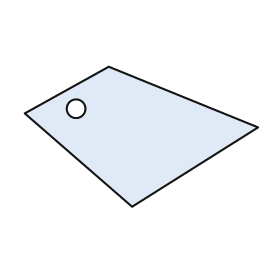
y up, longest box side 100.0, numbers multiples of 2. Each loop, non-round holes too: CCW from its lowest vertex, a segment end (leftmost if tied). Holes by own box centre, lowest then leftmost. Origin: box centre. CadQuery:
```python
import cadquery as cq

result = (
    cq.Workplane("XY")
    .moveTo(-4.0, -30.0)
    .lineTo(50.0, 4.0)
    .lineTo(-14.0, 30.0)
    .lineTo(-50.0, 10.0)
    .close()
    .moveTo(-28.0, 12.0)
    .circle(4.0)
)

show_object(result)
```